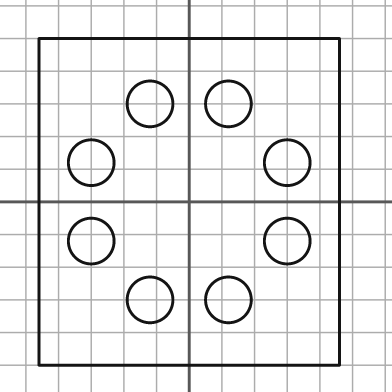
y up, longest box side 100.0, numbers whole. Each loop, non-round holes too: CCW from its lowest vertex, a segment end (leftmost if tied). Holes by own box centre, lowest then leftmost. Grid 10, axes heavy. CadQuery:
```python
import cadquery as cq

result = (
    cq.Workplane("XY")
    .moveTo(-46.0, -50.0)
    .lineTo(46.0, -50.0)
    .lineTo(46.0, 50.0)
    .lineTo(-46.0, 50.0)
    .close()
    .moveTo(-12.0, -30.0)
    .circle(7.0)
    .moveTo(12.0, -30.0)
    .circle(7.0)
    .moveTo(-30.0, -12.0)
    .circle(7.0)
    .moveTo(30.0, -12.0)
    .circle(7.0)
    .moveTo(-30.0, 12.0)
    .circle(7.0)
    .moveTo(30.0, 12.0)
    .circle(7.0)
    .moveTo(-12.0, 30.0)
    .circle(7.0)
    .moveTo(12.0, 30.0)
    .circle(7.0)
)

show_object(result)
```